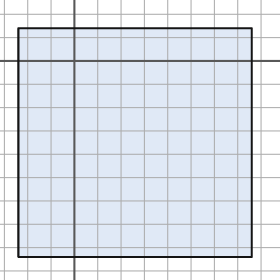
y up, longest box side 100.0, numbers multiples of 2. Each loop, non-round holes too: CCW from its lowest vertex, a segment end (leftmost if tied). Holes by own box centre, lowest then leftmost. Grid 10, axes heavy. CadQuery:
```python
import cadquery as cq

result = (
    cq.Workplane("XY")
    .moveTo(-24.0, -84.0)
    .lineTo(76.0, -84.0)
    .lineTo(76.0, 14.0)
    .lineTo(-24.0, 14.0)
    .close()
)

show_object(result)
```